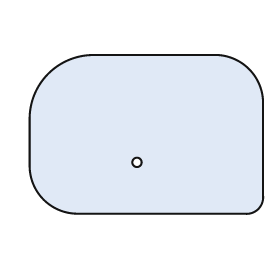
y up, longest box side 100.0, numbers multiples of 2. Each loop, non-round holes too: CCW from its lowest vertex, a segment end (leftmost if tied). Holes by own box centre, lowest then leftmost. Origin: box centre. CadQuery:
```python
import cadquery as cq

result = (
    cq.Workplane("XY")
    .moveTo(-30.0, -34.0)
    .lineTo(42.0, -34.0)
    .threePointArc((48.0, -32.0), (50.0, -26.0))
    .lineTo(50.0, 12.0)
    .threePointArc((44.0, 28.0), (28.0, 34.0))
    .lineTo(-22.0, 34.0)
    .threePointArc((-42.0, 26.0), (-50.0, 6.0))
    .lineTo(-50.0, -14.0)
    .threePointArc((-44.0, -28.0), (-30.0, -34.0))
    .close()
    .moveTo(-4.0, -12.0)
    .circle(2.0)
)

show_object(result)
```